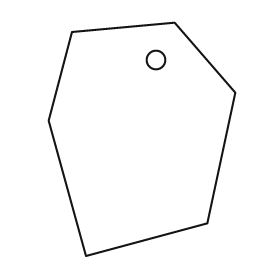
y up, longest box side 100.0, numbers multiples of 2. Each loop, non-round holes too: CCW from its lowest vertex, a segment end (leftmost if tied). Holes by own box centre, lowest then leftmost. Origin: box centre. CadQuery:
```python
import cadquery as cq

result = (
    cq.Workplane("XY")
    .moveTo(-24.0, -50.0)
    .lineTo(28.0, -36.0)
    .lineTo(40.0, 20.0)
    .lineTo(14.0, 50.0)
    .lineTo(-30.0, 46.0)
    .lineTo(-40.0, 8.0)
    .close()
    .moveTo(6.0, 34.0)
    .circle(4.0)
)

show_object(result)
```